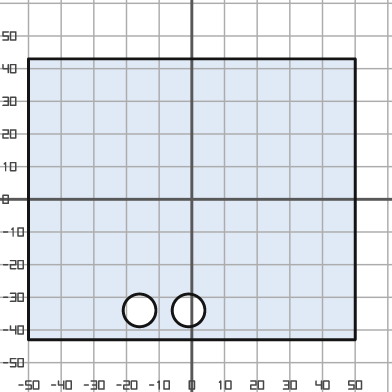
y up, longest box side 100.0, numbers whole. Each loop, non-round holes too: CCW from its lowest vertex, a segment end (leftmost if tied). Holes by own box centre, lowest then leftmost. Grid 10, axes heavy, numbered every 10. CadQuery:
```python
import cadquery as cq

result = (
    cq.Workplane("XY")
    .moveTo(-50.0, -43.0)
    .lineTo(50.0, -43.0)
    .lineTo(50.0, 43.0)
    .lineTo(-50.0, 43.0)
    .close()
    .moveTo(-16.0, -34.0)
    .circle(5.0)
    .moveTo(-1.0, -34.0)
    .circle(5.0)
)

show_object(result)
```